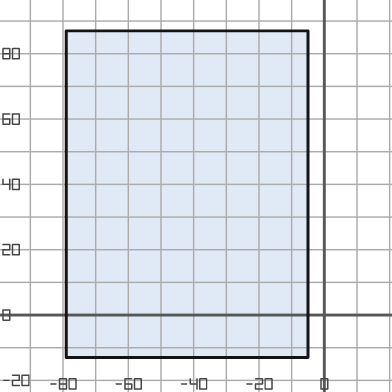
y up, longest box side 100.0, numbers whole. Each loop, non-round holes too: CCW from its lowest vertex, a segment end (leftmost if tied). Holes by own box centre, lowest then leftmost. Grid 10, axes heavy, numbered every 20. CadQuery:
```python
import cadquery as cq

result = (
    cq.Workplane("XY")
    .moveTo(-79.0, -13.0)
    .lineTo(-5.0, -13.0)
    .lineTo(-5.0, 87.0)
    .lineTo(-79.0, 87.0)
    .close()
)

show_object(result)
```